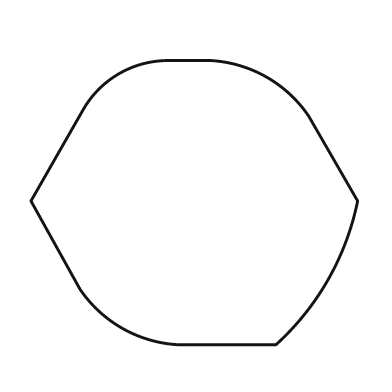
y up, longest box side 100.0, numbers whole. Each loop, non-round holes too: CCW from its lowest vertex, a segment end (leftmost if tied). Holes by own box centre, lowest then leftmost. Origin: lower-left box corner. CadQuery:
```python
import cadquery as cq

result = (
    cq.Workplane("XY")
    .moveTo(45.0, 0.0)
    .lineTo(75.0, 0.0)
    .threePointArc((91.0, 20.0), (100.0, 44.0))
    .lineTo(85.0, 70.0)
    .threePointArc((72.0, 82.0), (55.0, 87.0))
    .lineTo(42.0, 87.0)
    .threePointArc((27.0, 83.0), (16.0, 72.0))
    .lineTo(0.0, 44.0)
    .lineTo(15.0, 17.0)
    .threePointArc((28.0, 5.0), (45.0, 0.0))
    .close()
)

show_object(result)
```